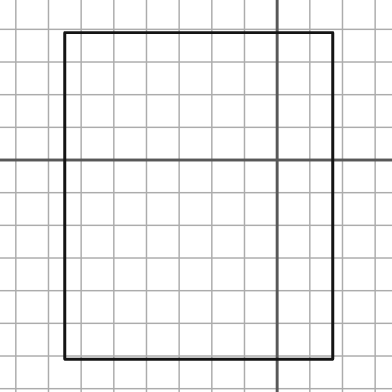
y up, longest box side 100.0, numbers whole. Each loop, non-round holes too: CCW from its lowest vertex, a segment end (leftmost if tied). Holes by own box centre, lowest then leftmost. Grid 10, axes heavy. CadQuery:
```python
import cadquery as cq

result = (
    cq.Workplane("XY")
    .moveTo(-65.0, -61.0)
    .lineTo(17.0, -61.0)
    .lineTo(17.0, 39.0)
    .lineTo(-65.0, 39.0)
    .close()
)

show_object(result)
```